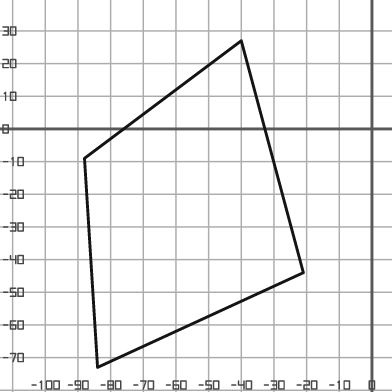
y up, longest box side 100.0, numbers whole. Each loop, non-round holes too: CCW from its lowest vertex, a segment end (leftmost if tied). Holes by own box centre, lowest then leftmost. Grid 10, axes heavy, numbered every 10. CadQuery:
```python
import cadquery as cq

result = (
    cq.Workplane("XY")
    .moveTo(-84.0, -73.0)
    .lineTo(-21.0, -44.0)
    .lineTo(-40.0, 27.0)
    .lineTo(-88.0, -9.0)
    .close()
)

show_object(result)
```